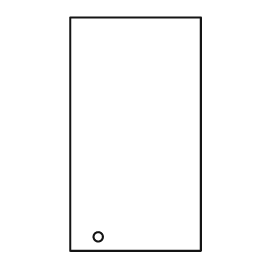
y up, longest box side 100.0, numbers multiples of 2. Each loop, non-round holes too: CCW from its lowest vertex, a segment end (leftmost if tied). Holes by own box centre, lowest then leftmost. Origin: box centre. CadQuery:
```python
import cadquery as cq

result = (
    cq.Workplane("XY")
    .moveTo(-28.0, -50.0)
    .lineTo(28.0, -50.0)
    .lineTo(28.0, 50.0)
    .lineTo(-28.0, 50.0)
    .close()
    .moveTo(-16.0, -44.0)
    .circle(2.0)
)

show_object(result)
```